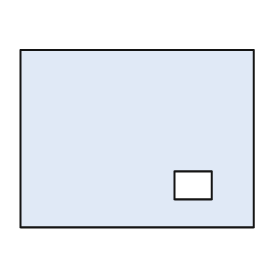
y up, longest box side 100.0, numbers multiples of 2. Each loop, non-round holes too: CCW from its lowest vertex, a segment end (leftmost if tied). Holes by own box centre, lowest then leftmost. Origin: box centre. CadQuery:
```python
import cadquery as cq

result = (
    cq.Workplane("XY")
    .moveTo(-50.0, -38.0)
    .lineTo(50.0, -38.0)
    .lineTo(50.0, 38.0)
    .lineTo(-50.0, 38.0)
    .close()
    .moveTo(16.0, -26.0)
    .lineTo(32.0, -26.0)
    .lineTo(32.0, -14.0)
    .lineTo(16.0, -14.0)
    .close()
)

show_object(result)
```